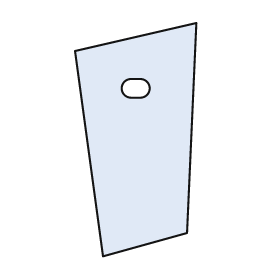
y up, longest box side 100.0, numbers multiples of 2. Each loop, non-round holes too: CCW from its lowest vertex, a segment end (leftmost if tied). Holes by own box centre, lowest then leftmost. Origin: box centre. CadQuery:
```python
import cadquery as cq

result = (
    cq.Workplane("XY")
    .moveTo(-14.0, -50.0)
    .lineTo(22.0, -40.0)
    .lineTo(26.0, 50.0)
    .lineTo(-26.0, 38.0)
    .close()
    .moveTo(-2.0, 18.0)
    .lineTo(2.0, 18.0)
    .threePointArc((6.0, 22.0), (2.0, 26.0))
    .lineTo(-2.0, 26.0)
    .threePointArc((-6.0, 22.0), (-2.0, 18.0))
    .close()
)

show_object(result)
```